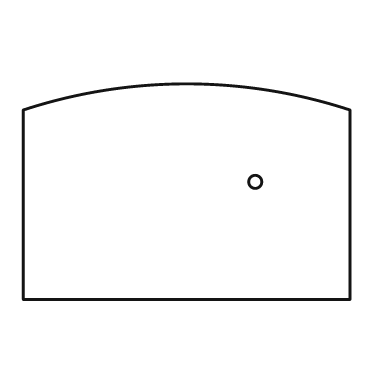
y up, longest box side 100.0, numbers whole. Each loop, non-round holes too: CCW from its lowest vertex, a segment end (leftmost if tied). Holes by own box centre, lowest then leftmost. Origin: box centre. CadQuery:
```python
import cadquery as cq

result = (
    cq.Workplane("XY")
    .moveTo(-50.0, -33.0)
    .lineTo(50.0, -33.0)
    .lineTo(50.0, 25.0)
    .threePointArc((0.0, 33.0), (-50.0, 25.0))
    .close()
    .moveTo(21.0, 3.0)
    .circle(2.0)
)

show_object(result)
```